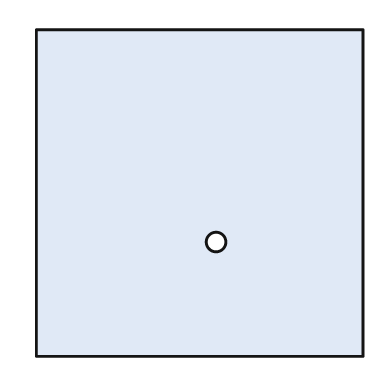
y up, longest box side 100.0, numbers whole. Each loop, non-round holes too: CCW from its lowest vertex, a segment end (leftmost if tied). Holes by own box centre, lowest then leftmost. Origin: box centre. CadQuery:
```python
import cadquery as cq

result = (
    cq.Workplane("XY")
    .moveTo(-50.0, -50.0)
    .lineTo(50.0, -50.0)
    .lineTo(50.0, 50.0)
    .lineTo(-50.0, 50.0)
    .close()
    .moveTo(5.0, -15.0)
    .circle(3.0)
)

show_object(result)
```